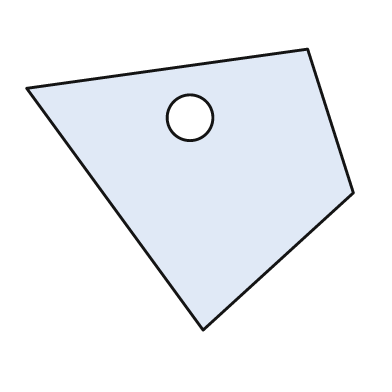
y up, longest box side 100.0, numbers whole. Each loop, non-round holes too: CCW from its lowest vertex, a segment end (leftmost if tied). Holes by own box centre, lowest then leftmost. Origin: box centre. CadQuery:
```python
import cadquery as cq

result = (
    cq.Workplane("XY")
    .moveTo(4.0, -43.0)
    .lineTo(50.0, -1.0)
    .lineTo(36.0, 43.0)
    .lineTo(-50.0, 31.0)
    .close()
    .moveTo(0.0, 22.0)
    .circle(7.0)
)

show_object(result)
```